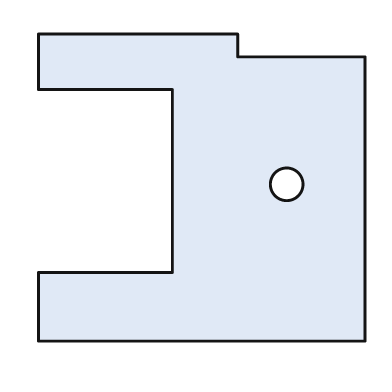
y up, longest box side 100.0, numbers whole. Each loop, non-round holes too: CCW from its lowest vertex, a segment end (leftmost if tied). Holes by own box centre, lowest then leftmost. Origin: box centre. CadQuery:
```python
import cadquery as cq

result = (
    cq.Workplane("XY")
    .moveTo(-50.0, -47.0)
    .lineTo(50.0, -47.0)
    .lineTo(50.0, 40.0)
    .lineTo(11.0, 40.0)
    .lineTo(11.0, 47.0)
    .lineTo(-50.0, 47.0)
    .lineTo(-50.0, 30.0)
    .lineTo(-9.0, 30.0)
    .lineTo(-9.0, -26.0)
    .lineTo(-50.0, -26.0)
    .close()
    .moveTo(26.0, 1.0)
    .circle(5.0)
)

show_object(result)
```